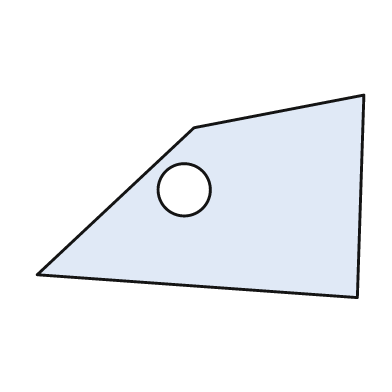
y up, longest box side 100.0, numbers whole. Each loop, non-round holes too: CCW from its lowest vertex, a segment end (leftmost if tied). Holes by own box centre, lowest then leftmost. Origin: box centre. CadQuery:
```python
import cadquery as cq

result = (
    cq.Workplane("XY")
    .moveTo(48.0, -31.0)
    .lineTo(50.0, 31.0)
    .lineTo(-2.0, 21.0)
    .lineTo(-50.0, -24.0)
    .close()
    .moveTo(-5.0, 2.0)
    .circle(8.0)
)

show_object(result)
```